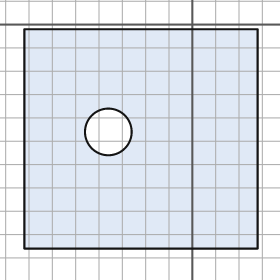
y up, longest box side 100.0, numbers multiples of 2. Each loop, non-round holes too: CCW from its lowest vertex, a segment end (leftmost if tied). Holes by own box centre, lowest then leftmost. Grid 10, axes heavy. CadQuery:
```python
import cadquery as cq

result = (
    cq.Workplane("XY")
    .moveTo(-72.0, -96.0)
    .lineTo(28.0, -96.0)
    .lineTo(28.0, -2.0)
    .lineTo(-72.0, -2.0)
    .close()
    .moveTo(-36.0, -46.0)
    .circle(10.0)
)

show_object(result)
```